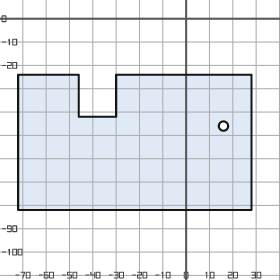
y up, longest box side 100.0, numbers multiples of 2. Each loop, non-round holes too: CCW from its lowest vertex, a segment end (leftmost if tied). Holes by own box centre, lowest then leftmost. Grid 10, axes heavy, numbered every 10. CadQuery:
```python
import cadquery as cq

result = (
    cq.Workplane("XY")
    .moveTo(-72.0, -82.0)
    .lineTo(28.0, -82.0)
    .lineTo(28.0, -24.0)
    .lineTo(-30.0, -24.0)
    .lineTo(-30.0, -42.0)
    .lineTo(-46.0, -42.0)
    .lineTo(-46.0, -24.0)
    .lineTo(-72.0, -24.0)
    .close()
    .moveTo(16.0, -46.0)
    .circle(2.0)
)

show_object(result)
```